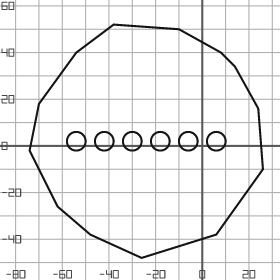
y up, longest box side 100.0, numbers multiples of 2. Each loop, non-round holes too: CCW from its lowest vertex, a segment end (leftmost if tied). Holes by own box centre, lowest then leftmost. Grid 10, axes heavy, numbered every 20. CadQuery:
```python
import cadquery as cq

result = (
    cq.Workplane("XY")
    .moveTo(-26.0, -48.0)
    .lineTo(6.0, -38.0)
    .lineTo(26.0, -10.0)
    .lineTo(24.0, 16.0)
    .lineTo(14.0, 34.0)
    .lineTo(8.0, 40.0)
    .lineTo(-10.0, 50.0)
    .lineTo(-38.0, 52.0)
    .lineTo(-54.0, 40.0)
    .lineTo(-70.0, 18.0)
    .lineTo(-74.0, -2.0)
    .lineTo(-62.0, -26.0)
    .lineTo(-48.0, -38.0)
    .close()
    .moveTo(-54.0, 2.0)
    .circle(4.0)
    .moveTo(-42.0, 2.0)
    .circle(4.0)
    .moveTo(-30.0, 2.0)
    .circle(4.0)
    .moveTo(-18.0, 2.0)
    .circle(4.0)
    .moveTo(-6.0, 2.0)
    .circle(4.0)
    .moveTo(6.0, 2.0)
    .circle(4.0)
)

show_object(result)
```